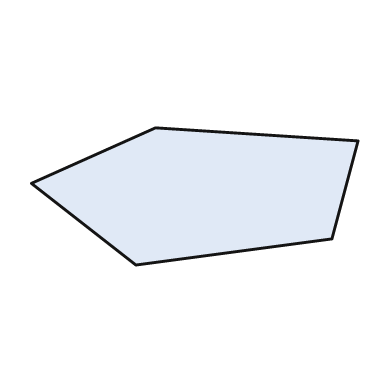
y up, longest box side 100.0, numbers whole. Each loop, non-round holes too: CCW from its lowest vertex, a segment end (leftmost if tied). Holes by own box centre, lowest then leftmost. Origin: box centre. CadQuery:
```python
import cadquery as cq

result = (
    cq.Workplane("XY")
    .moveTo(-18.0, -21.0)
    .lineTo(42.0, -13.0)
    .lineTo(50.0, 17.0)
    .lineTo(-12.0, 21.0)
    .lineTo(-50.0, 4.0)
    .close()
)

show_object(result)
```